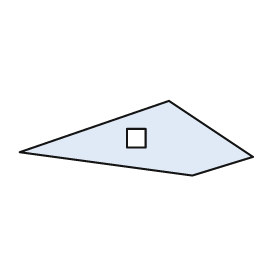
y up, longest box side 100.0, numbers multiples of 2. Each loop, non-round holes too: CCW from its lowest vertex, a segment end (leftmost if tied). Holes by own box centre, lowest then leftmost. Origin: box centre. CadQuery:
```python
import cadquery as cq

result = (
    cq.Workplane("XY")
    .moveTo(24.0, -16.0)
    .lineTo(50.0, -8.0)
    .lineTo(14.0, 16.0)
    .lineTo(-50.0, -6.0)
    .close()
    .moveTo(-4.0, -4.0)
    .lineTo(4.0, -4.0)
    .lineTo(4.0, 4.0)
    .lineTo(-4.0, 4.0)
    .close()
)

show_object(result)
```